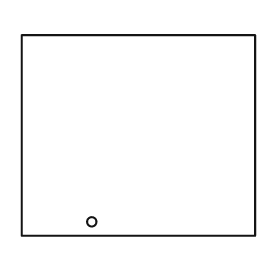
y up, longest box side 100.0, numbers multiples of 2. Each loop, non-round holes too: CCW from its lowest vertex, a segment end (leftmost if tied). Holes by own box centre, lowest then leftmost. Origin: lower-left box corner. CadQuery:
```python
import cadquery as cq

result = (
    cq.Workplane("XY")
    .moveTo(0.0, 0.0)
    .lineTo(100.0, 0.0)
    .lineTo(100.0, 86.0)
    .lineTo(0.0, 86.0)
    .close()
    .moveTo(30.0, 6.0)
    .circle(2.0)
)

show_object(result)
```